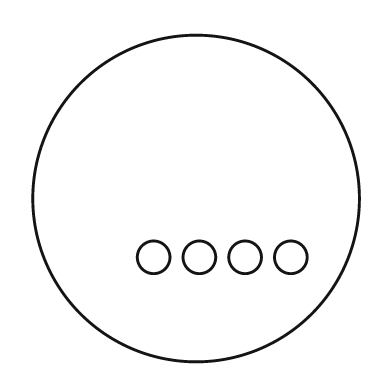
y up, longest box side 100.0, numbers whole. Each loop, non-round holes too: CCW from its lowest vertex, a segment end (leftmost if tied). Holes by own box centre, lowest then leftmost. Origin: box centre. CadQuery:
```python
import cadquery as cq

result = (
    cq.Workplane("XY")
    .moveTo(0.0, 0.0)
    .circle(50.0)
    .moveTo(-13.0, -18.0)
    .circle(5.0)
    .moveTo(1.0, -18.0)
    .circle(5.0)
    .moveTo(15.0, -18.0)
    .circle(5.0)
    .moveTo(29.0, -18.0)
    .circle(5.0)
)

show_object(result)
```